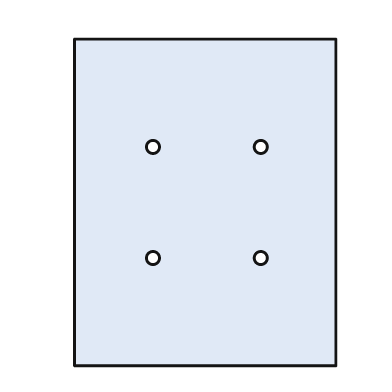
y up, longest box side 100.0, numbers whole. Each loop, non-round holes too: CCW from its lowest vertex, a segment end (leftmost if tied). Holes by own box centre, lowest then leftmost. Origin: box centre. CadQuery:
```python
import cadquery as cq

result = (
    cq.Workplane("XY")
    .moveTo(-40.0, -50.0)
    .lineTo(40.0, -50.0)
    .lineTo(40.0, 50.0)
    .lineTo(-40.0, 50.0)
    .close()
    .moveTo(-16.0, -17.0)
    .circle(2.0)
    .moveTo(17.0, -17.0)
    .circle(2.0)
    .moveTo(-16.0, 17.0)
    .circle(2.0)
    .moveTo(17.0, 17.0)
    .circle(2.0)
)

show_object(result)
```